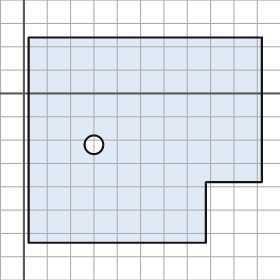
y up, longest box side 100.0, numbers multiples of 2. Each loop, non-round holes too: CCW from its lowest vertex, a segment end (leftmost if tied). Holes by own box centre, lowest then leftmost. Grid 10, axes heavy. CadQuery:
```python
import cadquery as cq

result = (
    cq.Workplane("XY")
    .moveTo(2.0, -64.0)
    .lineTo(78.0, -64.0)
    .lineTo(78.0, -38.0)
    .lineTo(102.0, -38.0)
    .lineTo(102.0, 24.0)
    .lineTo(2.0, 24.0)
    .close()
    .moveTo(30.0, -22.0)
    .circle(4.0)
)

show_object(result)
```